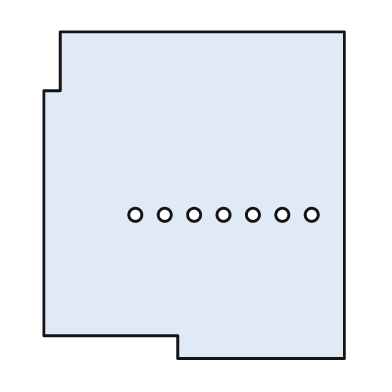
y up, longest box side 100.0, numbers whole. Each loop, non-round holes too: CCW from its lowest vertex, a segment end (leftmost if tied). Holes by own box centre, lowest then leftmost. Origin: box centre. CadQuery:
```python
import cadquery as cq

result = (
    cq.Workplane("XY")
    .moveTo(-5.0, -50.0)
    .lineTo(46.0, -50.0)
    .lineTo(46.0, 50.0)
    .lineTo(-41.0, 50.0)
    .lineTo(-41.0, 32.0)
    .lineTo(-46.0, 32.0)
    .lineTo(-46.0, -43.0)
    .lineTo(-5.0, -43.0)
    .close()
    .moveTo(-18.0, -6.0)
    .circle(2.0)
    .moveTo(-9.0, -6.0)
    .circle(2.0)
    .moveTo(0.0, -6.0)
    .circle(2.0)
    .moveTo(9.0, -6.0)
    .circle(2.0)
    .moveTo(18.0, -6.0)
    .circle(2.0)
    .moveTo(27.0, -6.0)
    .circle(2.0)
    .moveTo(36.0, -6.0)
    .circle(2.0)
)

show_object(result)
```